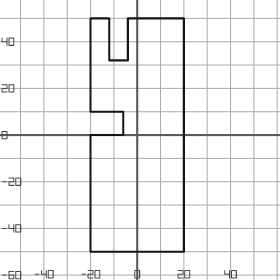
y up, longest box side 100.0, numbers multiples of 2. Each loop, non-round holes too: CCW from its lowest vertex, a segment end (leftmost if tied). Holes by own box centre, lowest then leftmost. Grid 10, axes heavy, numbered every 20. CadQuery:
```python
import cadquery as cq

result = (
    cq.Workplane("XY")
    .moveTo(-20.0, -50.0)
    .lineTo(20.0, -50.0)
    .lineTo(20.0, 50.0)
    .lineTo(-4.0, 50.0)
    .lineTo(-4.0, 32.0)
    .lineTo(-12.0, 32.0)
    .lineTo(-12.0, 50.0)
    .lineTo(-20.0, 50.0)
    .lineTo(-20.0, 10.0)
    .lineTo(-6.0, 10.0)
    .lineTo(-6.0, 0.0)
    .lineTo(-20.0, 0.0)
    .close()
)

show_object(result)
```